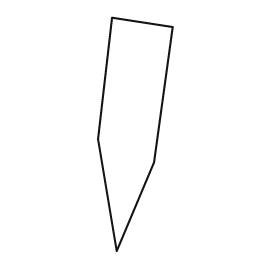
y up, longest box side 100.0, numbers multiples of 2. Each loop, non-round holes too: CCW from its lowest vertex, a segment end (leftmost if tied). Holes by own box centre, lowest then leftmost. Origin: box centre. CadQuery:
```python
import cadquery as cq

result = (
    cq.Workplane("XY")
    .moveTo(-8.0, -50.0)
    .lineTo(8.0, -12.0)
    .lineTo(16.0, 46.0)
    .lineTo(-10.0, 50.0)
    .lineTo(-16.0, -2.0)
    .close()
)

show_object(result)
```